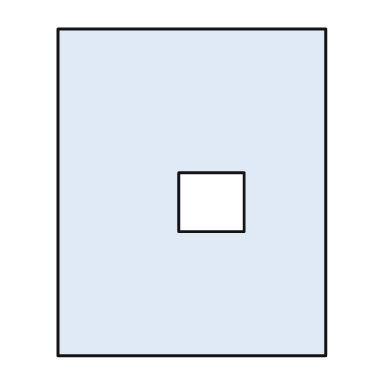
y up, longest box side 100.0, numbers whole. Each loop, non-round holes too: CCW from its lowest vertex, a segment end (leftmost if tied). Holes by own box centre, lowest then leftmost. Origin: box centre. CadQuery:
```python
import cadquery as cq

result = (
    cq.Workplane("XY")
    .moveTo(-41.0, -50.0)
    .lineTo(41.0, -50.0)
    .lineTo(41.0, 50.0)
    .lineTo(-41.0, 50.0)
    .close()
    .moveTo(-4.0, -12.0)
    .lineTo(16.0, -12.0)
    .lineTo(16.0, 6.0)
    .lineTo(-4.0, 6.0)
    .close()
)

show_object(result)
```